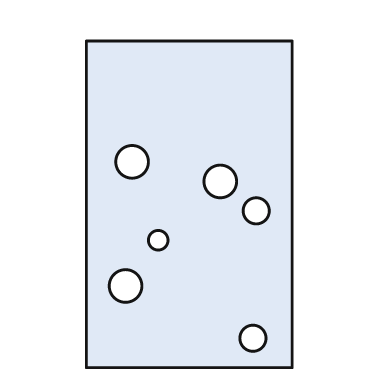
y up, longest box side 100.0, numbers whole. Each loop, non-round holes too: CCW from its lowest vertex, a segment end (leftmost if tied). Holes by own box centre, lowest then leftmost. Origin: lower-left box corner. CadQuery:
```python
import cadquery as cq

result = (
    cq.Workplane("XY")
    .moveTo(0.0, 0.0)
    .lineTo(63.0, 0.0)
    .lineTo(63.0, 100.0)
    .lineTo(0.0, 100.0)
    .close()
    .moveTo(51.0, 9.0)
    .circle(4.0)
    .moveTo(12.0, 25.0)
    .circle(5.0)
    .moveTo(22.0, 39.0)
    .circle(3.0)
    .moveTo(52.0, 48.0)
    .circle(4.0)
    .moveTo(41.0, 57.0)
    .circle(5.0)
    .moveTo(14.0, 63.0)
    .circle(5.0)
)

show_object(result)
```